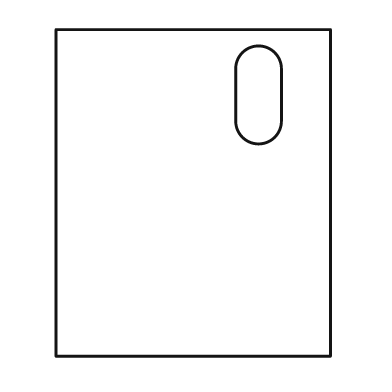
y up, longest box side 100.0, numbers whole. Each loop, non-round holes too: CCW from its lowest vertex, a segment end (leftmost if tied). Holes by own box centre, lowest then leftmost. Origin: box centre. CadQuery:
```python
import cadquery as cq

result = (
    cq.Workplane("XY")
    .moveTo(-42.0, -50.0)
    .lineTo(42.0, -50.0)
    .lineTo(42.0, 50.0)
    .lineTo(-42.0, 50.0)
    .close()
    .moveTo(13.0, 22.0)
    .threePointArc((20.0, 15.0), (27.0, 22.0))
    .lineTo(27.0, 38.0)
    .threePointArc((20.0, 45.0), (13.0, 38.0))
    .close()
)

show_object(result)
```